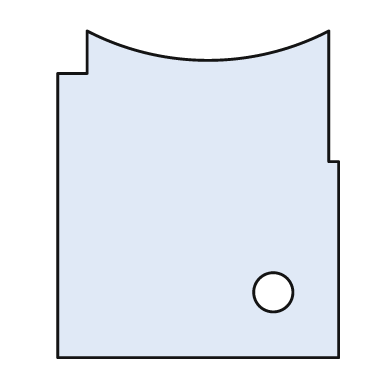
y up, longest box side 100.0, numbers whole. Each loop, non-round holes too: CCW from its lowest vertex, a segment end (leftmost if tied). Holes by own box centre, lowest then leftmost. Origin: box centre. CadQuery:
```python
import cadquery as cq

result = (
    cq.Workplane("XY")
    .moveTo(-43.0, -50.0)
    .lineTo(43.0, -50.0)
    .lineTo(43.0, 10.0)
    .lineTo(40.0, 10.0)
    .lineTo(40.0, 50.0)
    .threePointArc((3.0, 41.0), (-34.0, 50.0))
    .lineTo(-34.0, 37.0)
    .lineTo(-43.0, 37.0)
    .close()
    .moveTo(23.0, -30.0)
    .circle(6.0)
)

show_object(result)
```